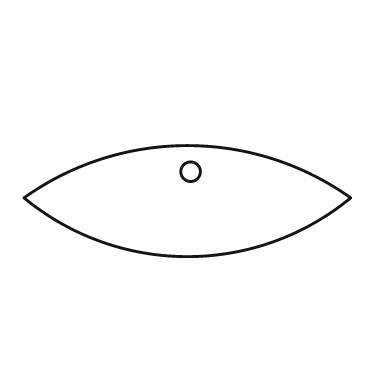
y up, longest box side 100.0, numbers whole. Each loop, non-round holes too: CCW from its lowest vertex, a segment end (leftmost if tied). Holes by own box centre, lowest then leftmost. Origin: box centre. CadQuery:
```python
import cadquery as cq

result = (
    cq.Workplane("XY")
    .moveTo(-50.0, 1.0)
    .threePointArc((0.0, -17.0), (50.0, 1.0))
    .threePointArc((0.0, 17.0), (-50.0, 1.0))
    .close()
    .moveTo(1.0, 9.0)
    .circle(3.0)
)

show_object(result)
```